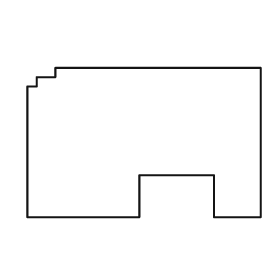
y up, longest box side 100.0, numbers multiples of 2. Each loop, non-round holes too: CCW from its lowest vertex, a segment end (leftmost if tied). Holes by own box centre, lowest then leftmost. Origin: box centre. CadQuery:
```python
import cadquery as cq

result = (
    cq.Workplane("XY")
    .moveTo(-50.0, -32.0)
    .lineTo(-2.0, -32.0)
    .lineTo(-2.0, -14.0)
    .lineTo(30.0, -14.0)
    .lineTo(30.0, -32.0)
    .lineTo(50.0, -32.0)
    .lineTo(50.0, 32.0)
    .lineTo(-38.0, 32.0)
    .lineTo(-38.0, 28.0)
    .lineTo(-46.0, 28.0)
    .lineTo(-46.0, 24.0)
    .lineTo(-50.0, 24.0)
    .close()
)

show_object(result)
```